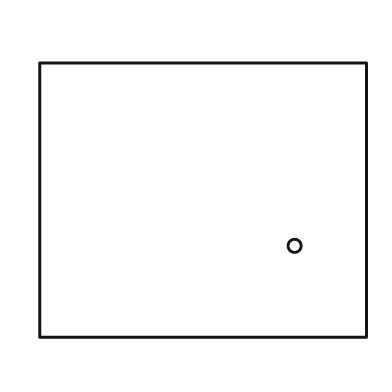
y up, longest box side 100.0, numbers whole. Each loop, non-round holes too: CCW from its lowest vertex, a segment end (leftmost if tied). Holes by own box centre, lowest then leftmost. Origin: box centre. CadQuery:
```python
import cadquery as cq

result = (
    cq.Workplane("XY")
    .moveTo(-50.0, -42.0)
    .lineTo(50.0, -42.0)
    .lineTo(50.0, 42.0)
    .lineTo(-50.0, 42.0)
    .close()
    .moveTo(28.0, -14.0)
    .circle(2.0)
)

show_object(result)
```